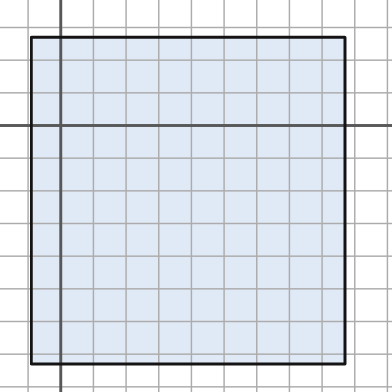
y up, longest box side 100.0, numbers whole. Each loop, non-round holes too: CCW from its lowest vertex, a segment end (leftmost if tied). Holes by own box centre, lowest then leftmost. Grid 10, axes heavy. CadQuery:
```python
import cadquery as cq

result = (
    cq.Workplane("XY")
    .moveTo(-9.0, -73.0)
    .lineTo(87.0, -73.0)
    .lineTo(87.0, 27.0)
    .lineTo(-9.0, 27.0)
    .close()
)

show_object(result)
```